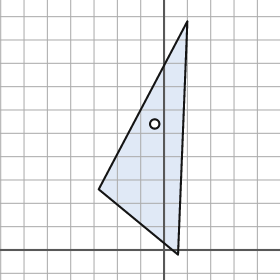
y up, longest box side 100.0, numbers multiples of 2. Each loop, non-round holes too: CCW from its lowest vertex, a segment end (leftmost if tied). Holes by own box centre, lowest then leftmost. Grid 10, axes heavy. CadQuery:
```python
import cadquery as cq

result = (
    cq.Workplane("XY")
    .moveTo(6.0, -2.0)
    .lineTo(10.0, 98.0)
    .lineTo(-28.0, 26.0)
    .close()
    .moveTo(-4.0, 54.0)
    .circle(2.0)
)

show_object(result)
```